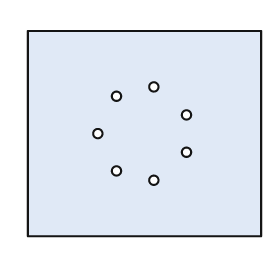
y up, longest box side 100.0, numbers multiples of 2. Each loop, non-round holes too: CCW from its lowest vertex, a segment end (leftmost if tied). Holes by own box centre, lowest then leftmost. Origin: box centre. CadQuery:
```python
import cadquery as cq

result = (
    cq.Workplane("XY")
    .moveTo(-50.0, -44.0)
    .lineTo(50.0, -44.0)
    .lineTo(50.0, 44.0)
    .lineTo(-50.0, 44.0)
    .close()
    .moveTo(4.0, -20.0)
    .circle(2.0)
    .moveTo(-12.0, -16.0)
    .circle(2.0)
    .moveTo(18.0, -8.0)
    .circle(2.0)
    .moveTo(-20.0, 0.0)
    .circle(2.0)
    .moveTo(18.0, 8.0)
    .circle(2.0)
    .moveTo(-12.0, 16.0)
    .circle(2.0)
    .moveTo(4.0, 20.0)
    .circle(2.0)
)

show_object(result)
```